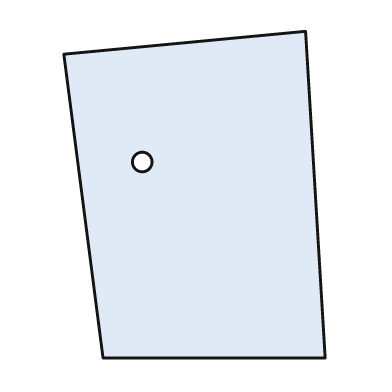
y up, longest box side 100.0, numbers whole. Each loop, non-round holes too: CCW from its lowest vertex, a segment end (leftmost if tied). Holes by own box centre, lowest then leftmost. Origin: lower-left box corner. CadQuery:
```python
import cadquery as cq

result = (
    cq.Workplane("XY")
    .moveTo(12.0, 0.0)
    .lineTo(80.0, 0.0)
    .lineTo(74.0, 100.0)
    .lineTo(0.0, 93.0)
    .close()
    .moveTo(24.0, 60.0)
    .circle(3.0)
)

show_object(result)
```